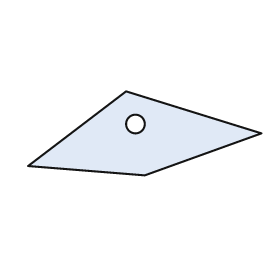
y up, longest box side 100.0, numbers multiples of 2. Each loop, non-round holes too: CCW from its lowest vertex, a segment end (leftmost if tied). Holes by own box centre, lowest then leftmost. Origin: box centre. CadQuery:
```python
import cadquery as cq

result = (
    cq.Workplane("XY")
    .moveTo(0.0, -18.0)
    .lineTo(50.0, 0.0)
    .lineTo(-8.0, 18.0)
    .lineTo(-50.0, -14.0)
    .close()
    .moveTo(-4.0, 4.0)
    .circle(4.0)
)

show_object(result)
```